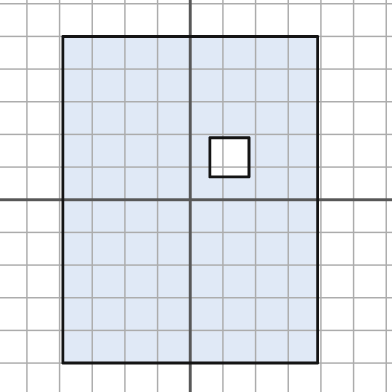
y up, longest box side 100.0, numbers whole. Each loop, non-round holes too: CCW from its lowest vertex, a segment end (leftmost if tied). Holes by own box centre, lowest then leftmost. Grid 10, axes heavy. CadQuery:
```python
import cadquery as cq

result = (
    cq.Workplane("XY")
    .moveTo(-39.0, -50.0)
    .lineTo(39.0, -50.0)
    .lineTo(39.0, 50.0)
    .lineTo(-39.0, 50.0)
    .close()
    .moveTo(6.0, 7.0)
    .lineTo(18.0, 7.0)
    .lineTo(18.0, 19.0)
    .lineTo(6.0, 19.0)
    .close()
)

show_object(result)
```